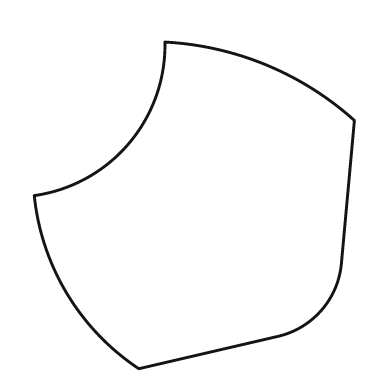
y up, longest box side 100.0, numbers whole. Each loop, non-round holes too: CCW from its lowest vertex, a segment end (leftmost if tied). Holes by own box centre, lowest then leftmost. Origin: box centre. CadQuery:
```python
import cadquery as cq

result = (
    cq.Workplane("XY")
    .moveTo(-17.0, -50.0)
    .lineTo(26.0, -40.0)
    .threePointArc((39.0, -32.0), (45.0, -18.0))
    .lineTo(49.0, 26.0)
    .threePointArc((22.0, 43.0), (-9.0, 50.0))
    .threePointArc((-20.0, 19.0), (-49.0, 3.0))
    .threePointArc((-39.0, -27.0), (-17.0, -50.0))
    .close()
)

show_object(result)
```